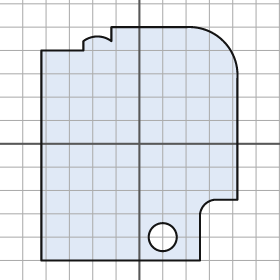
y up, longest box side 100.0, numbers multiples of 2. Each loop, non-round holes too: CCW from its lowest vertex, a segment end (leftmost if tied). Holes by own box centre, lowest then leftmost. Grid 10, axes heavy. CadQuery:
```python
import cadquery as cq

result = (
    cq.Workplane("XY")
    .moveTo(-42.0, -50.0)
    .lineTo(26.0, -50.0)
    .lineTo(26.0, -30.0)
    .threePointArc((28.0, -26.0), (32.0, -24.0))
    .lineTo(42.0, -24.0)
    .lineTo(42.0, 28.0)
    .threePointArc((36.0, 44.0), (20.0, 50.0))
    .lineTo(-12.0, 50.0)
    .lineTo(-12.0, 44.0)
    .threePointArc((-18.0, 46.0), (-24.0, 44.0))
    .lineTo(-24.0, 40.0)
    .lineTo(-42.0, 40.0)
    .close()
    .moveTo(10.0, -40.0)
    .circle(6.0)
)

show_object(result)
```